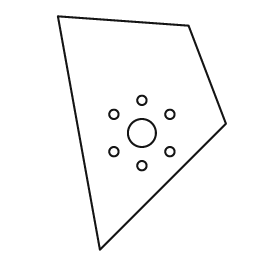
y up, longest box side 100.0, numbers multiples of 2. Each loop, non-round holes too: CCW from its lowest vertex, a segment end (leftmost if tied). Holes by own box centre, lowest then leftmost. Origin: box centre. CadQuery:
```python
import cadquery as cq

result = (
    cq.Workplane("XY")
    .moveTo(-18.0, -50.0)
    .lineTo(36.0, 4.0)
    .lineTo(20.0, 46.0)
    .lineTo(-36.0, 50.0)
    .close()
    .moveTo(0.0, -14.0)
    .circle(2.0)
    .moveTo(-12.0, -8.0)
    .circle(2.0)
    .moveTo(12.0, -8.0)
    .circle(2.0)
    .moveTo(0.0, 0.0)
    .circle(6.0)
    .moveTo(-12.0, 8.0)
    .circle(2.0)
    .moveTo(12.0, 8.0)
    .circle(2.0)
    .moveTo(0.0, 14.0)
    .circle(2.0)
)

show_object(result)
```